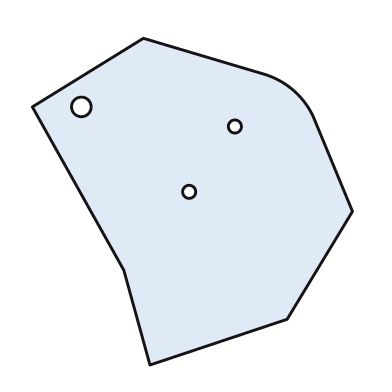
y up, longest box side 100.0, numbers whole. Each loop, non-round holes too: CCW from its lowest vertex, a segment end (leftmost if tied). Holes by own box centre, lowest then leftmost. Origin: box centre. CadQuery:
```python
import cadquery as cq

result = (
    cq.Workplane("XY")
    .moveTo(-13.0, -50.0)
    .lineTo(29.0, -36.0)
    .lineTo(49.0, -3.0)
    .lineTo(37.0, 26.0)
    .threePointArc((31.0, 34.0), (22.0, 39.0))
    .lineTo(-15.0, 50.0)
    .lineTo(-49.0, 29.0)
    .lineTo(-21.0, -21.0)
    .close()
    .moveTo(-1.0, 3.0)
    .circle(2.0)
    .moveTo(13.0, 23.0)
    .circle(2.0)
    .moveTo(-34.0, 29.0)
    .circle(3.0)
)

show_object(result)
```